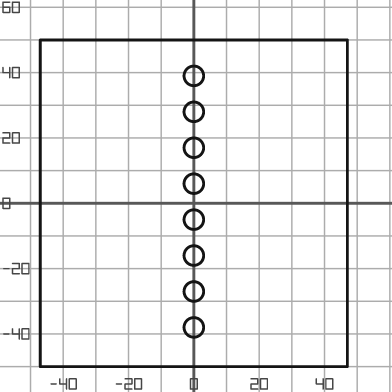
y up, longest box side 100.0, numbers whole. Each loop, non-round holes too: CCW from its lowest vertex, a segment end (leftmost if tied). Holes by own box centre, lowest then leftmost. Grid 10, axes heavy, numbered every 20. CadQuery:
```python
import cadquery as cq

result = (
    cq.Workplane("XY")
    .moveTo(-47.0, -50.0)
    .lineTo(47.0, -50.0)
    .lineTo(47.0, 50.0)
    .lineTo(-47.0, 50.0)
    .close()
    .moveTo(0.0, -38.0)
    .circle(3.0)
    .moveTo(0.0, -27.0)
    .circle(3.0)
    .moveTo(0.0, -16.0)
    .circle(3.0)
    .moveTo(0.0, -5.0)
    .circle(3.0)
    .moveTo(0.0, 6.0)
    .circle(3.0)
    .moveTo(0.0, 17.0)
    .circle(3.0)
    .moveTo(0.0, 28.0)
    .circle(3.0)
    .moveTo(0.0, 39.0)
    .circle(3.0)
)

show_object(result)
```